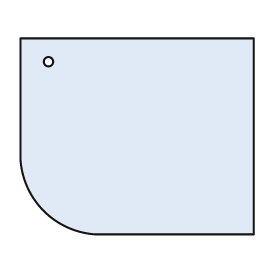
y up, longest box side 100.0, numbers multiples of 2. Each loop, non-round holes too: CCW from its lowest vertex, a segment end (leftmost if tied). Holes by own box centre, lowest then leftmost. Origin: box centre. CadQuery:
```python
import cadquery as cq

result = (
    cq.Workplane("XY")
    .moveTo(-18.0, -42.0)
    .lineTo(50.0, -42.0)
    .lineTo(50.0, 42.0)
    .lineTo(-50.0, 42.0)
    .lineTo(-50.0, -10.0)
    .threePointArc((-40.0, -32.0), (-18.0, -42.0))
    .close()
    .moveTo(-38.0, 32.0)
    .circle(2.0)
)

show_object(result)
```